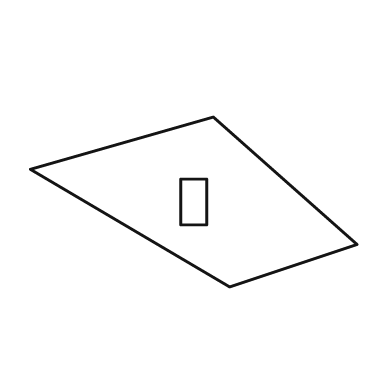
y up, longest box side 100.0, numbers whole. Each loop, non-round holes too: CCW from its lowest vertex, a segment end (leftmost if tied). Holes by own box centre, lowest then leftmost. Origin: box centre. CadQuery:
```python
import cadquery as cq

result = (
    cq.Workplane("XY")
    .moveTo(11.0, -26.0)
    .lineTo(50.0, -13.0)
    .lineTo(6.0, 26.0)
    .lineTo(-50.0, 10.0)
    .close()
    .moveTo(-4.0, -7.0)
    .lineTo(4.0, -7.0)
    .lineTo(4.0, 7.0)
    .lineTo(-4.0, 7.0)
    .close()
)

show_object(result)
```